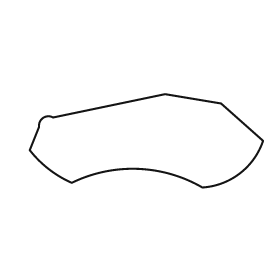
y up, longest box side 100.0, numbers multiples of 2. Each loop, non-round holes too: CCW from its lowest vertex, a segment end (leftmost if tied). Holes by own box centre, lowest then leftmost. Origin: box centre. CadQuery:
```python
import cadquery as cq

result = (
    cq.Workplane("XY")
    .moveTo(24.0, -20.0)
    .threePointArc((40.0, -14.0), (50.0, 0.0))
    .lineTo(32.0, 16.0)
    .lineTo(8.0, 20.0)
    .lineTo(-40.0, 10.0)
    .threePointArc((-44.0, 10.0), (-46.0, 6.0))
    .lineTo(-50.0, -4.0)
    .threePointArc((-42.0, -12.0), (-32.0, -18.0))
    .threePointArc((-4.0, -12.0), (24.0, -20.0))
    .close()
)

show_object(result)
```